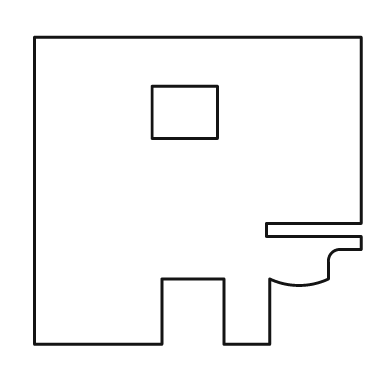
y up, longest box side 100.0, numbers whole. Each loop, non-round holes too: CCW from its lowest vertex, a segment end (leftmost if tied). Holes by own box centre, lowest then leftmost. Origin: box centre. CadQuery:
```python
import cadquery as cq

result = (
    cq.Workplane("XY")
    .moveTo(-50.0, -47.0)
    .lineTo(-11.0, -47.0)
    .lineTo(-11.0, -27.0)
    .lineTo(8.0, -27.0)
    .lineTo(8.0, -47.0)
    .lineTo(22.0, -47.0)
    .lineTo(22.0, -27.0)
    .threePointArc((31.0, -29.0), (40.0, -27.0))
    .lineTo(40.0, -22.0)
    .threePointArc((41.0, -19.0), (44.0, -18.0))
    .lineTo(50.0, -18.0)
    .lineTo(50.0, -14.0)
    .lineTo(21.0, -14.0)
    .lineTo(21.0, -10.0)
    .lineTo(50.0, -10.0)
    .lineTo(50.0, 47.0)
    .lineTo(-50.0, 47.0)
    .close()
    .moveTo(-14.0, 16.0)
    .lineTo(6.0, 16.0)
    .lineTo(6.0, 32.0)
    .lineTo(-14.0, 32.0)
    .close()
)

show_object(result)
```